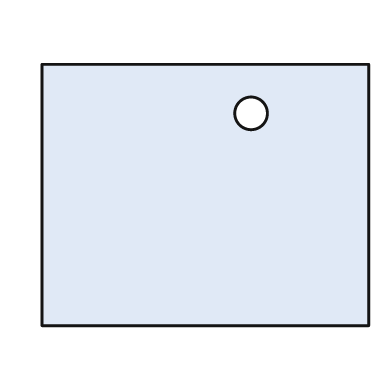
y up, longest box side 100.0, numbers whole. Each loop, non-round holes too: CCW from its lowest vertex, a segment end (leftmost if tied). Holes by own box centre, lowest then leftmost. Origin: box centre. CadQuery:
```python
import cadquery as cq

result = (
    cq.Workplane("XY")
    .moveTo(-50.0, -40.0)
    .lineTo(50.0, -40.0)
    .lineTo(50.0, 40.0)
    .lineTo(-50.0, 40.0)
    .close()
    .moveTo(14.0, 25.0)
    .circle(5.0)
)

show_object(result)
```